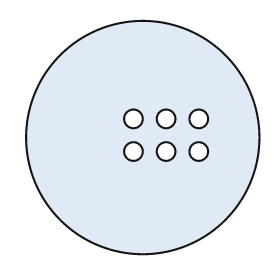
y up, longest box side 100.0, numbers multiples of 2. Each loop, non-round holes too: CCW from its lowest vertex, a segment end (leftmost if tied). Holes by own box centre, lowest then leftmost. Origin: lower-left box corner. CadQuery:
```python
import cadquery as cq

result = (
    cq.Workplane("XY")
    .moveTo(50.0, 50.0)
    .circle(50.0)
    .moveTo(46.0, 44.0)
    .circle(4.0)
    .moveTo(60.0, 44.0)
    .circle(4.0)
    .moveTo(74.0, 44.0)
    .circle(4.0)
    .moveTo(46.0, 58.0)
    .circle(4.0)
    .moveTo(60.0, 58.0)
    .circle(4.0)
    .moveTo(74.0, 58.0)
    .circle(4.0)
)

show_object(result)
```